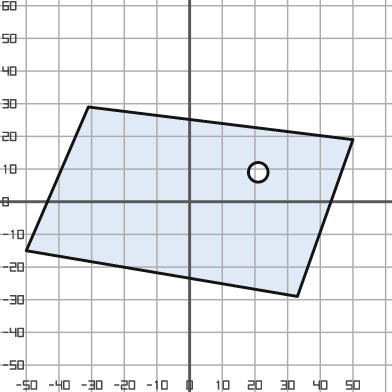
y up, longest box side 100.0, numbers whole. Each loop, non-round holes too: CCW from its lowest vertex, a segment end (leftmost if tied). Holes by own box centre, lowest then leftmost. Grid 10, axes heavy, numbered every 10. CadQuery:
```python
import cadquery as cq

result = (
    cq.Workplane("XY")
    .moveTo(33.0, -29.0)
    .lineTo(50.0, 19.0)
    .lineTo(-31.0, 29.0)
    .lineTo(-50.0, -15.0)
    .close()
    .moveTo(21.0, 9.0)
    .circle(3.0)
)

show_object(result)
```